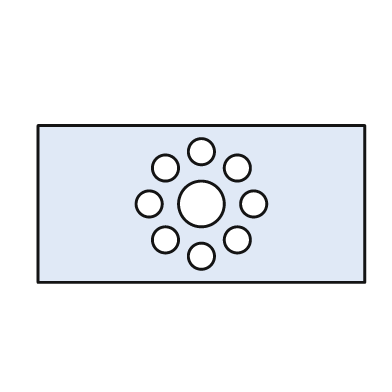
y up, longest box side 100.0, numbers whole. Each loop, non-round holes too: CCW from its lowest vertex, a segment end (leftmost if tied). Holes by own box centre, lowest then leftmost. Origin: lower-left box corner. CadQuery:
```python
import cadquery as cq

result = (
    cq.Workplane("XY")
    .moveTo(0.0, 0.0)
    .lineTo(100.0, 0.0)
    .lineTo(100.0, 48.0)
    .lineTo(0.0, 48.0)
    .close()
    .moveTo(50.0, 8.0)
    .circle(4.0)
    .moveTo(39.0, 13.0)
    .circle(4.0)
    .moveTo(61.0, 13.0)
    .circle(4.0)
    .moveTo(34.0, 24.0)
    .circle(4.0)
    .moveTo(50.0, 24.0)
    .circle(7.0)
    .moveTo(66.0, 24.0)
    .circle(4.0)
    .moveTo(39.0, 35.0)
    .circle(4.0)
    .moveTo(61.0, 35.0)
    .circle(4.0)
    .moveTo(50.0, 40.0)
    .circle(4.0)
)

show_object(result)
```